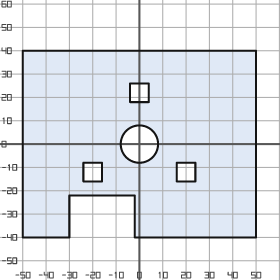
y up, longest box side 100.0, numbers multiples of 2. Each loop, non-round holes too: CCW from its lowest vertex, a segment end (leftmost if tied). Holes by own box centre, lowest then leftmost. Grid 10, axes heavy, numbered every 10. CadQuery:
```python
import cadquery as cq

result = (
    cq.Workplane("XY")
    .moveTo(-50.0, -40.0)
    .lineTo(-30.0, -40.0)
    .lineTo(-30.0, -22.0)
    .lineTo(-2.0, -22.0)
    .lineTo(-2.0, -40.0)
    .lineTo(50.0, -40.0)
    .lineTo(50.0, 40.0)
    .lineTo(-50.0, 40.0)
    .close()
    .moveTo(-24.0, -16.0)
    .lineTo(-16.0, -16.0)
    .lineTo(-16.0, -8.0)
    .lineTo(-24.0, -8.0)
    .close()
    .moveTo(16.0, -16.0)
    .lineTo(24.0, -16.0)
    .lineTo(24.0, -8.0)
    .lineTo(16.0, -8.0)
    .close()
    .moveTo(0.0, 0.0)
    .circle(8.0)
    .moveTo(-4.0, 18.0)
    .lineTo(4.0, 18.0)
    .lineTo(4.0, 26.0)
    .lineTo(-4.0, 26.0)
    .close()
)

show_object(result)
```